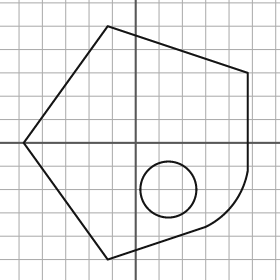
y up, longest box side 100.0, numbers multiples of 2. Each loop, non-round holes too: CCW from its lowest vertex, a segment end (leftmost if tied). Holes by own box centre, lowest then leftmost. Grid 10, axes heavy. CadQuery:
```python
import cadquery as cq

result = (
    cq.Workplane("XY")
    .moveTo(-12.0, -50.0)
    .lineTo(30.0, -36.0)
    .threePointArc((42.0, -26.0), (48.0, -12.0))
    .lineTo(48.0, 30.0)
    .lineTo(-12.0, 50.0)
    .lineTo(-48.0, 0.0)
    .close()
    .moveTo(14.0, -20.0)
    .circle(12.0)
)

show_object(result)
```